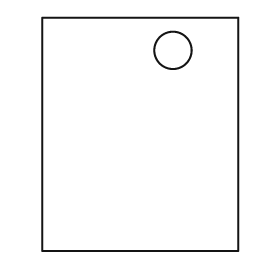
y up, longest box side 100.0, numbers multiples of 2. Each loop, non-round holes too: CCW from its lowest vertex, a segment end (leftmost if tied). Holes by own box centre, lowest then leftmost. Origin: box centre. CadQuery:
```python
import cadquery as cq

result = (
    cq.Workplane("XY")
    .moveTo(-42.0, -50.0)
    .lineTo(42.0, -50.0)
    .lineTo(42.0, 50.0)
    .lineTo(-42.0, 50.0)
    .close()
    .moveTo(14.0, 36.0)
    .circle(8.0)
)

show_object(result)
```